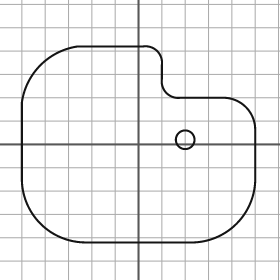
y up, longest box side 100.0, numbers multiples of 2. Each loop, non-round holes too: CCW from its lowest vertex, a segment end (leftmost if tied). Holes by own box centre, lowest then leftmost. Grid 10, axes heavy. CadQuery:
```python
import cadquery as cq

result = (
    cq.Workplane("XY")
    .moveTo(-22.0, -42.0)
    .lineTo(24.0, -42.0)
    .threePointArc((42.0, -34.0), (50.0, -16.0))
    .lineTo(50.0, 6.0)
    .threePointArc((46.0, 16.0), (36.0, 20.0))
    .lineTo(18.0, 20.0)
    .threePointArc((12.0, 22.0), (10.0, 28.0))
    .lineTo(10.0, 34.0)
    .threePointArc((8.0, 40.0), (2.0, 42.0))
    .lineTo(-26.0, 42.0)
    .threePointArc((-42.0, 34.0), (-50.0, 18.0))
    .lineTo(-50.0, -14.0)
    .threePointArc((-42.0, -34.0), (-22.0, -42.0))
    .close()
    .moveTo(20.0, 2.0)
    .circle(4.0)
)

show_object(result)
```